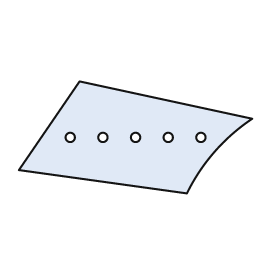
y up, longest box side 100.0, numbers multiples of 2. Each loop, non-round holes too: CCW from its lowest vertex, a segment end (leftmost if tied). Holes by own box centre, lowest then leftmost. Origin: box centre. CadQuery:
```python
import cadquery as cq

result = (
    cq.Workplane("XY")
    .moveTo(22.0, -24.0)
    .threePointArc((34.0, -6.0), (50.0, 8.0))
    .lineTo(-24.0, 24.0)
    .lineTo(-50.0, -14.0)
    .close()
    .moveTo(-28.0, 0.0)
    .circle(2.0)
    .moveTo(-14.0, 0.0)
    .circle(2.0)
    .moveTo(0.0, 0.0)
    .circle(2.0)
    .moveTo(14.0, 0.0)
    .circle(2.0)
    .moveTo(28.0, 0.0)
    .circle(2.0)
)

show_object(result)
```